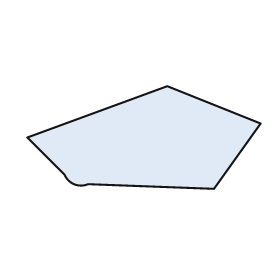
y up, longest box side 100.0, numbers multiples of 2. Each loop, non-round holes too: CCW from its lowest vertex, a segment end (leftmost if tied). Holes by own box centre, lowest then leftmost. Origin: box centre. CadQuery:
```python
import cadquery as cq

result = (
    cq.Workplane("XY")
    .moveTo(30.0, -22.0)
    .lineTo(50.0, 6.0)
    .lineTo(10.0, 22.0)
    .lineTo(-50.0, 0.0)
    .lineTo(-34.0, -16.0)
    .threePointArc((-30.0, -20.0), (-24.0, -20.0))
    .close()
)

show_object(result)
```